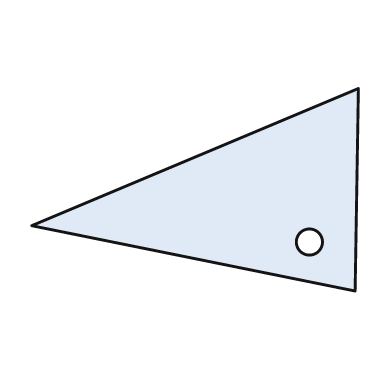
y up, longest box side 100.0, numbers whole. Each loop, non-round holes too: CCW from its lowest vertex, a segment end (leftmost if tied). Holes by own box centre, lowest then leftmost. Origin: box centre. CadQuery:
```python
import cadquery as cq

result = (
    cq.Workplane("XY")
    .moveTo(49.0, -31.0)
    .lineTo(50.0, 31.0)
    .lineTo(-50.0, -11.0)
    .close()
    .moveTo(35.0, -16.0)
    .circle(4.0)
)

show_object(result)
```